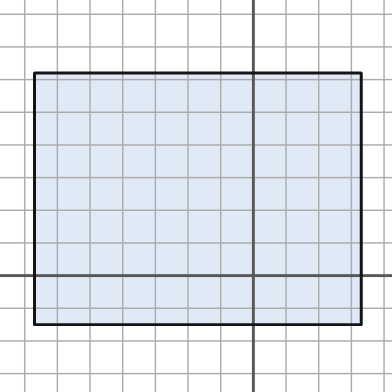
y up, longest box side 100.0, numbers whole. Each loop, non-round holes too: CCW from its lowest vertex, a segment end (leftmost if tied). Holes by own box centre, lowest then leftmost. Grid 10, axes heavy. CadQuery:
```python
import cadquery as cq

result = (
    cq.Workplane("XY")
    .moveTo(-67.0, -15.0)
    .lineTo(33.0, -15.0)
    .lineTo(33.0, 62.0)
    .lineTo(-67.0, 62.0)
    .close()
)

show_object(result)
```